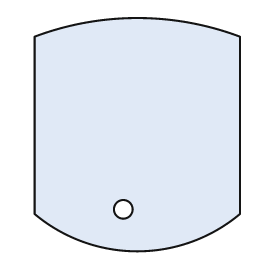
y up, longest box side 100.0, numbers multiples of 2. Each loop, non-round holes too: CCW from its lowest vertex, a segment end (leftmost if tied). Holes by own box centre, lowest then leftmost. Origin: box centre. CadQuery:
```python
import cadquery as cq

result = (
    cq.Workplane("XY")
    .moveTo(-44.0, -34.0)
    .threePointArc((0.0, -50.0), (44.0, -34.0))
    .lineTo(44.0, 42.0)
    .threePointArc((0.0, 50.0), (-44.0, 42.0))
    .close()
    .moveTo(-6.0, -32.0)
    .circle(4.0)
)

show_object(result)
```